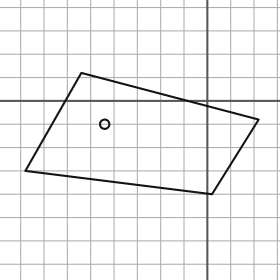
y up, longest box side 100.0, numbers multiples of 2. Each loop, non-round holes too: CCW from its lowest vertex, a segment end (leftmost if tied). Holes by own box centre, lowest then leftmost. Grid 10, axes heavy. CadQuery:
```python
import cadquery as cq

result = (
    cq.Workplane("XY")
    .moveTo(2.0, -40.0)
    .lineTo(22.0, -8.0)
    .lineTo(-54.0, 12.0)
    .lineTo(-78.0, -30.0)
    .close()
    .moveTo(-44.0, -10.0)
    .circle(2.0)
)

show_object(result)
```